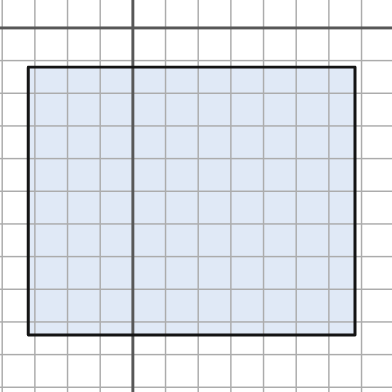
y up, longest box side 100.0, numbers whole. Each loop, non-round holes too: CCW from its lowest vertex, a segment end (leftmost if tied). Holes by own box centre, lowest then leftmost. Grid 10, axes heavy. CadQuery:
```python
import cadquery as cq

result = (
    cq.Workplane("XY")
    .moveTo(-32.0, -94.0)
    .lineTo(68.0, -94.0)
    .lineTo(68.0, -12.0)
    .lineTo(-32.0, -12.0)
    .close()
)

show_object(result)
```